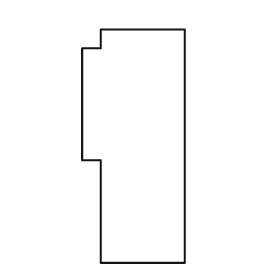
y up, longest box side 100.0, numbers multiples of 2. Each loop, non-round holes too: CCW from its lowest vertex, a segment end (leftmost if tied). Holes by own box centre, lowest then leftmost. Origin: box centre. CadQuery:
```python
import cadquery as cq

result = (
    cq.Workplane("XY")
    .moveTo(-14.0, -50.0)
    .lineTo(22.0, -50.0)
    .lineTo(22.0, 50.0)
    .lineTo(-14.0, 50.0)
    .lineTo(-14.0, 42.0)
    .lineTo(-22.0, 42.0)
    .lineTo(-22.0, -6.0)
    .lineTo(-14.0, -6.0)
    .close()
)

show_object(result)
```